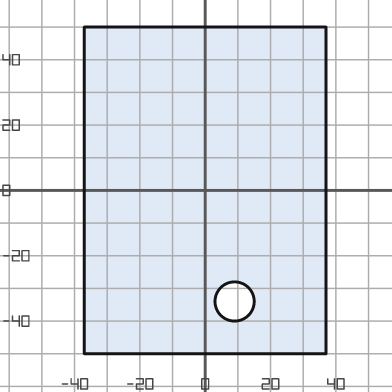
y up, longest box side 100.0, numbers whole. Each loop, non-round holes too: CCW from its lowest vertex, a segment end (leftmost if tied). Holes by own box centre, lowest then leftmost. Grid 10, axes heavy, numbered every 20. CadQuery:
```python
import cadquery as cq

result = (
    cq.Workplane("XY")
    .moveTo(-37.0, -50.0)
    .lineTo(37.0, -50.0)
    .lineTo(37.0, 50.0)
    .lineTo(-37.0, 50.0)
    .close()
    .moveTo(9.0, -34.0)
    .circle(6.0)
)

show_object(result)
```